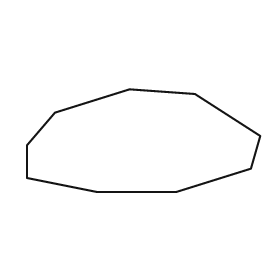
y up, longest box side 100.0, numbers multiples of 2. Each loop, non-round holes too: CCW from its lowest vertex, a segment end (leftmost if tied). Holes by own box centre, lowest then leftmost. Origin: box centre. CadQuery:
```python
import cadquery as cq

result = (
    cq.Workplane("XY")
    .moveTo(-20.0, -22.0)
    .lineTo(14.0, -22.0)
    .lineTo(46.0, -12.0)
    .lineTo(50.0, 2.0)
    .lineTo(22.0, 20.0)
    .lineTo(-6.0, 22.0)
    .lineTo(-38.0, 12.0)
    .lineTo(-50.0, -2.0)
    .lineTo(-50.0, -16.0)
    .close()
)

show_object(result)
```